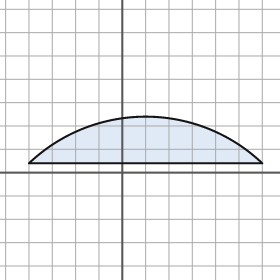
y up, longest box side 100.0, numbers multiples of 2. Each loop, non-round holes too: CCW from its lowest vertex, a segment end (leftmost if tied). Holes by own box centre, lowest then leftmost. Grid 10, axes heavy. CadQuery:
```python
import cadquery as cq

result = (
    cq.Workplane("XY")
    .moveTo(-40.0, 4.0)
    .lineTo(60.0, 4.0)
    .threePointArc((10.0, 24.0), (-40.0, 4.0))
    .close()
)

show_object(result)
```